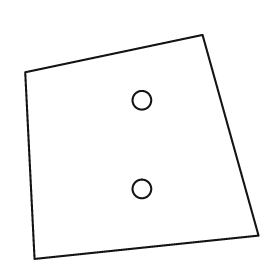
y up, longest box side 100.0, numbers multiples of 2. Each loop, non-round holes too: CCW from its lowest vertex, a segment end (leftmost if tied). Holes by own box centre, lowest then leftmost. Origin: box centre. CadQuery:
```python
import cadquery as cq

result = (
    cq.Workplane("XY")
    .moveTo(-46.0, -48.0)
    .lineTo(50.0, -38.0)
    .lineTo(26.0, 48.0)
    .lineTo(-50.0, 32.0)
    .close()
    .moveTo(0.0, -18.0)
    .circle(4.0)
    .moveTo(0.0, 20.0)
    .circle(4.0)
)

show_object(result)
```